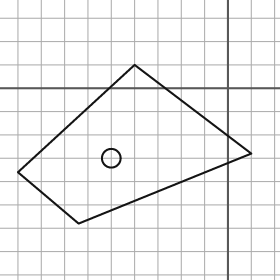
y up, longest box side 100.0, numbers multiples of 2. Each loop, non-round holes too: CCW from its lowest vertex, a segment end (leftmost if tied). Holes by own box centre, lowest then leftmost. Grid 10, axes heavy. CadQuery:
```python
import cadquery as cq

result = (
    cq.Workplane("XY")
    .moveTo(-64.0, -58.0)
    .lineTo(10.0, -28.0)
    .lineTo(-40.0, 10.0)
    .lineTo(-90.0, -36.0)
    .close()
    .moveTo(-50.0, -30.0)
    .circle(4.0)
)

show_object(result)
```